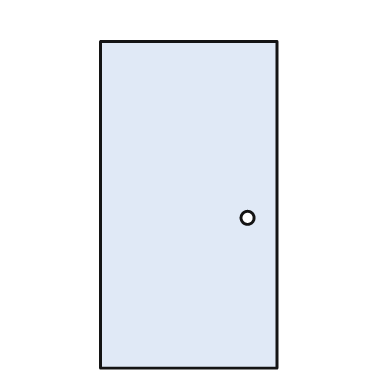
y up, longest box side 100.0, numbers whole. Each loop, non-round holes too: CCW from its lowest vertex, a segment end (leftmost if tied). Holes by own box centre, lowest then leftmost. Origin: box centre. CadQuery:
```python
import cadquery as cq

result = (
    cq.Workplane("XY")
    .moveTo(-27.0, -50.0)
    .lineTo(27.0, -50.0)
    .lineTo(27.0, 50.0)
    .lineTo(-27.0, 50.0)
    .close()
    .moveTo(18.0, -4.0)
    .circle(2.0)
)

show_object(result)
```